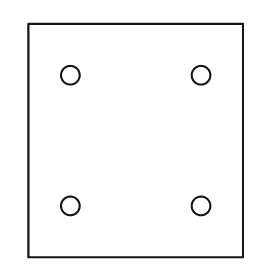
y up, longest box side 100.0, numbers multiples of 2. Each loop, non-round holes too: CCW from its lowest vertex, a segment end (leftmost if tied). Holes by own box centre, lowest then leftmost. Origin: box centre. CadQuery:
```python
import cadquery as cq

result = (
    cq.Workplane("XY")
    .moveTo(-46.0, -50.0)
    .lineTo(46.0, -50.0)
    .lineTo(46.0, 50.0)
    .lineTo(-46.0, 50.0)
    .close()
    .moveTo(-28.0, -28.0)
    .circle(4.0)
    .moveTo(28.0, -28.0)
    .circle(4.0)
    .moveTo(-28.0, 28.0)
    .circle(4.0)
    .moveTo(28.0, 28.0)
    .circle(4.0)
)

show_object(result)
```